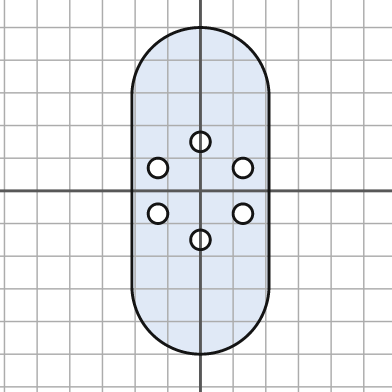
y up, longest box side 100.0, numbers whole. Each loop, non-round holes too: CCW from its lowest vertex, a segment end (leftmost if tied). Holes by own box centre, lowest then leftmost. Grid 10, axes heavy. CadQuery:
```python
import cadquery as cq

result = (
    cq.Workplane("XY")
    .moveTo(-21.0, -29.0)
    .threePointArc((0.0, -50.0), (21.0, -29.0))
    .lineTo(21.0, 29.0)
    .threePointArc((0.0, 50.0), (-21.0, 29.0))
    .close()
    .moveTo(0.0, -15.0)
    .circle(3.0)
    .moveTo(-13.0, -7.0)
    .circle(3.0)
    .moveTo(13.0, -7.0)
    .circle(3.0)
    .moveTo(-13.0, 7.0)
    .circle(3.0)
    .moveTo(13.0, 7.0)
    .circle(3.0)
    .moveTo(0.0, 15.0)
    .circle(3.0)
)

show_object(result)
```